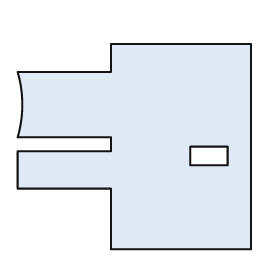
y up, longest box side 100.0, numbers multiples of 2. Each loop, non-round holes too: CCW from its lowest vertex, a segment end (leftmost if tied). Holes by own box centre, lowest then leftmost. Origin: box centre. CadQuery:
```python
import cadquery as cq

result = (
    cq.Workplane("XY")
    .moveTo(-10.0, -44.0)
    .lineTo(50.0, -44.0)
    .lineTo(50.0, 44.0)
    .lineTo(-10.0, 44.0)
    .lineTo(-10.0, 32.0)
    .lineTo(-50.0, 32.0)
    .threePointArc((-48.0, 18.0), (-50.0, 4.0))
    .lineTo(-10.0, 4.0)
    .lineTo(-10.0, -2.0)
    .lineTo(-50.0, -2.0)
    .lineTo(-50.0, -18.0)
    .lineTo(-10.0, -18.0)
    .close()
    .moveTo(24.0, -8.0)
    .lineTo(40.0, -8.0)
    .lineTo(40.0, 0.0)
    .lineTo(24.0, 0.0)
    .close()
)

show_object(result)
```